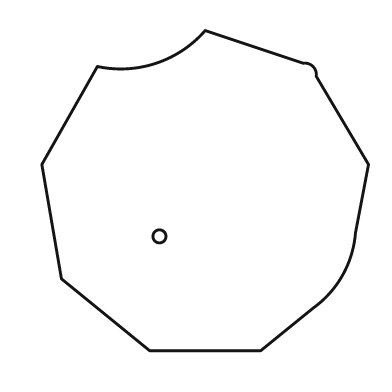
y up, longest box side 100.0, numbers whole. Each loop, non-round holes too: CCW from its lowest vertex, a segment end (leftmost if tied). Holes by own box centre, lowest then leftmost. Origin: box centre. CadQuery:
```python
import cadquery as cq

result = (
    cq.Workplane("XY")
    .moveTo(-17.0, -49.0)
    .lineTo(17.0, -49.0)
    .lineTo(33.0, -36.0)
    .threePointArc((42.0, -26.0), (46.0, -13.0))
    .lineTo(50.0, 8.0)
    .lineTo(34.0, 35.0)
    .threePointArc((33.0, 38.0), (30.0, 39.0))
    .lineTo(0.0, 49.0)
    .threePointArc((-15.0, 39.0), (-33.0, 38.0))
    .lineTo(-50.0, 8.0)
    .lineTo(-44.0, -27.0)
    .close()
    .moveTo(-14.0, -14.0)
    .circle(2.0)
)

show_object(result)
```